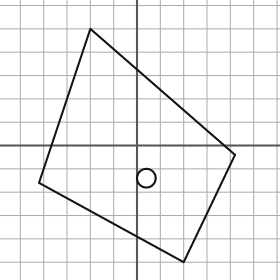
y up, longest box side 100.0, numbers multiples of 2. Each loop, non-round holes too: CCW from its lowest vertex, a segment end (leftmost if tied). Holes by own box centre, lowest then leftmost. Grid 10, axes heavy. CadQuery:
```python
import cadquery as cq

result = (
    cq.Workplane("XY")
    .moveTo(20.0, -50.0)
    .lineTo(42.0, -4.0)
    .lineTo(-20.0, 50.0)
    .lineTo(-42.0, -16.0)
    .close()
    .moveTo(4.0, -14.0)
    .circle(4.0)
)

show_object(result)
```